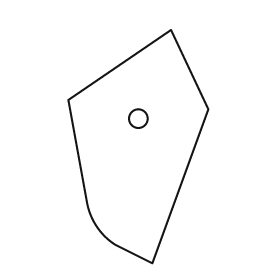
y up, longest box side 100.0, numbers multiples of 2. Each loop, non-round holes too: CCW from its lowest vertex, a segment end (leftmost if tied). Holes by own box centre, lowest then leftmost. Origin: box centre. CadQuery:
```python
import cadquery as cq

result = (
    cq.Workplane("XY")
    .moveTo(6.0, -50.0)
    .lineTo(30.0, 16.0)
    .lineTo(14.0, 50.0)
    .lineTo(-30.0, 20.0)
    .lineTo(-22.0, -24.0)
    .threePointArc((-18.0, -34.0), (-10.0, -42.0))
    .close()
    .moveTo(0.0, 12.0)
    .circle(4.0)
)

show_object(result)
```